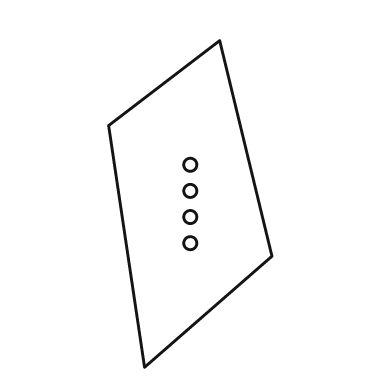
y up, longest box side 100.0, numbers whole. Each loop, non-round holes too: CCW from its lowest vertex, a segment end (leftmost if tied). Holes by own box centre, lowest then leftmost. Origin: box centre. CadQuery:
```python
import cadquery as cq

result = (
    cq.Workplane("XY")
    .moveTo(-14.0, -50.0)
    .lineTo(25.0, -16.0)
    .lineTo(9.0, 50.0)
    .lineTo(-25.0, 24.0)
    .close()
    .moveTo(0.0, -12.0)
    .circle(2.0)
    .moveTo(0.0, -4.0)
    .circle(2.0)
    .moveTo(0.0, 4.0)
    .circle(2.0)
    .moveTo(0.0, 12.0)
    .circle(2.0)
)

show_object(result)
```